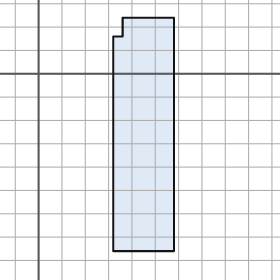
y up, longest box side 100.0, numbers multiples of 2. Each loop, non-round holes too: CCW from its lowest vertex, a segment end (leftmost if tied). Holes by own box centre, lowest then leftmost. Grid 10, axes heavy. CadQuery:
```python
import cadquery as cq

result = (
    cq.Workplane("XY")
    .moveTo(32.0, -76.0)
    .lineTo(58.0, -76.0)
    .lineTo(58.0, 24.0)
    .lineTo(36.0, 24.0)
    .lineTo(36.0, 16.0)
    .lineTo(32.0, 16.0)
    .close()
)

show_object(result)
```